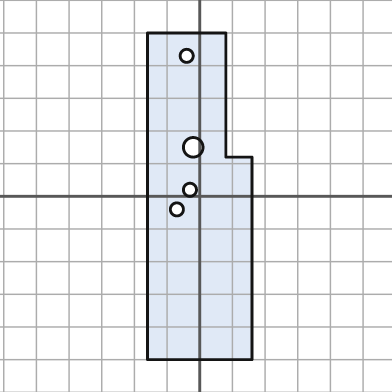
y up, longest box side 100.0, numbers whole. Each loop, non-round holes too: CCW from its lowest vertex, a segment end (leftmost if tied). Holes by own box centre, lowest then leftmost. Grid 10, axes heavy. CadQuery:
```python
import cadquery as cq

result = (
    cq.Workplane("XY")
    .moveTo(-16.0, -50.0)
    .lineTo(16.0, -50.0)
    .lineTo(16.0, 12.0)
    .lineTo(8.0, 12.0)
    .lineTo(8.0, 50.0)
    .lineTo(-16.0, 50.0)
    .close()
    .moveTo(-7.0, -4.0)
    .circle(2.0)
    .moveTo(-3.0, 2.0)
    .circle(2.0)
    .moveTo(-2.0, 15.0)
    .circle(3.0)
    .moveTo(-4.0, 43.0)
    .circle(2.0)
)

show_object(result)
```